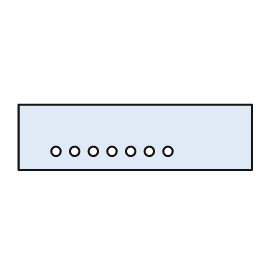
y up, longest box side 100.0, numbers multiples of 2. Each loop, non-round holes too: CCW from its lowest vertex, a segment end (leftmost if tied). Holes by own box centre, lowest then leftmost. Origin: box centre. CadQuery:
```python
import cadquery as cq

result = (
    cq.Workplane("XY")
    .moveTo(-50.0, -14.0)
    .lineTo(50.0, -14.0)
    .lineTo(50.0, 14.0)
    .lineTo(-50.0, 14.0)
    .close()
    .moveTo(-34.0, -6.0)
    .circle(2.0)
    .moveTo(-26.0, -6.0)
    .circle(2.0)
    .moveTo(-18.0, -6.0)
    .circle(2.0)
    .moveTo(-10.0, -6.0)
    .circle(2.0)
    .moveTo(-2.0, -6.0)
    .circle(2.0)
    .moveTo(6.0, -6.0)
    .circle(2.0)
    .moveTo(14.0, -6.0)
    .circle(2.0)
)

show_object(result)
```